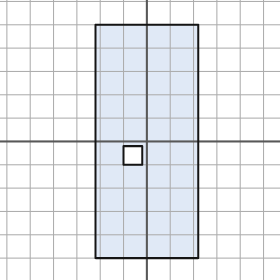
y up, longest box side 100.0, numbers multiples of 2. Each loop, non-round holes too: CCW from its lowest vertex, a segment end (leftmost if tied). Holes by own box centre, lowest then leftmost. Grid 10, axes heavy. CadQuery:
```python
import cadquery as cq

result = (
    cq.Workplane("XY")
    .moveTo(-22.0, -50.0)
    .lineTo(22.0, -50.0)
    .lineTo(22.0, 50.0)
    .lineTo(-22.0, 50.0)
    .close()
    .moveTo(-10.0, -10.0)
    .lineTo(-2.0, -10.0)
    .lineTo(-2.0, -2.0)
    .lineTo(-10.0, -2.0)
    .close()
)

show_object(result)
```